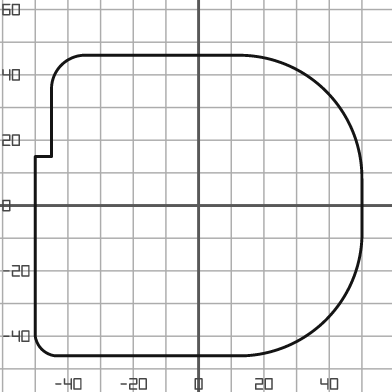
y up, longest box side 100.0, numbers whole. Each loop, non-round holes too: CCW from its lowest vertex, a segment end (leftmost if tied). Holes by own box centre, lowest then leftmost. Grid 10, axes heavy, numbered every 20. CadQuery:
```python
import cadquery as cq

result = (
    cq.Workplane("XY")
    .moveTo(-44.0, -46.0)
    .lineTo(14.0, -46.0)
    .threePointArc((39.0, -35.0), (50.0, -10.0))
    .lineTo(50.0, 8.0)
    .threePointArc((39.0, 35.0), (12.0, 46.0))
    .lineTo(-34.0, 46.0)
    .threePointArc((-42.0, 43.0), (-45.0, 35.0))
    .lineTo(-45.0, 15.0)
    .lineTo(-50.0, 15.0)
    .lineTo(-50.0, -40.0)
    .threePointArc((-48.0, -44.0), (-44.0, -46.0))
    .close()
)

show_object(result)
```